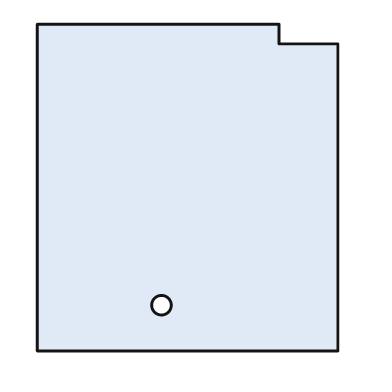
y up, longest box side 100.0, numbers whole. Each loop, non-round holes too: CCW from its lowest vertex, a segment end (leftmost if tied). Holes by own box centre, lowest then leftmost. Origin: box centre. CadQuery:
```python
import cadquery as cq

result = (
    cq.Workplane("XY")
    .moveTo(-46.0, -50.0)
    .lineTo(46.0, -50.0)
    .lineTo(46.0, 44.0)
    .lineTo(28.0, 44.0)
    .lineTo(28.0, 50.0)
    .lineTo(-46.0, 50.0)
    .close()
    .moveTo(-8.0, -36.0)
    .circle(3.0)
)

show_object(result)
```